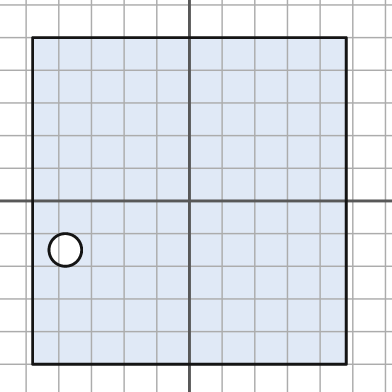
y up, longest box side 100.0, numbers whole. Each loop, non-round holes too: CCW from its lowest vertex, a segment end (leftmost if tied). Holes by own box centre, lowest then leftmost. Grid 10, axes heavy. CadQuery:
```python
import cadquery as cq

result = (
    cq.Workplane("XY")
    .moveTo(-48.0, -50.0)
    .lineTo(48.0, -50.0)
    .lineTo(48.0, 50.0)
    .lineTo(-48.0, 50.0)
    .close()
    .moveTo(-38.0, -15.0)
    .circle(5.0)
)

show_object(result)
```